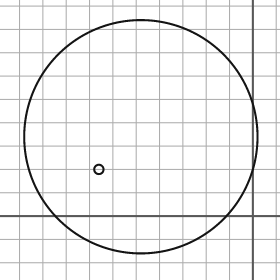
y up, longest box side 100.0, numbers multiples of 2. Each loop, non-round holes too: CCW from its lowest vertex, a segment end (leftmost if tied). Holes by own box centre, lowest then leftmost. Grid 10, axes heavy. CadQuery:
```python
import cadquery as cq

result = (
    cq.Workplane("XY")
    .moveTo(-48.0, 34.0)
    .circle(50.0)
    .moveTo(-66.0, 20.0)
    .circle(2.0)
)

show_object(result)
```